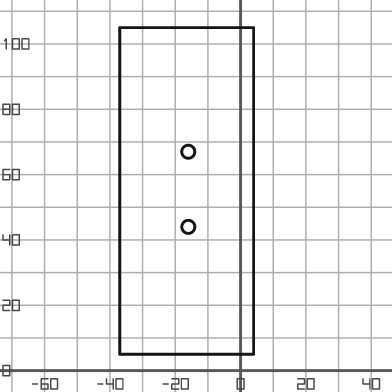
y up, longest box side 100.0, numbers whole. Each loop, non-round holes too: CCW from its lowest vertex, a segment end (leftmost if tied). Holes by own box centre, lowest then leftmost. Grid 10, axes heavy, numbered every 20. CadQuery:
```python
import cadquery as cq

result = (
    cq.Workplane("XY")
    .moveTo(-37.0, 5.0)
    .lineTo(4.0, 5.0)
    .lineTo(4.0, 105.0)
    .lineTo(-37.0, 105.0)
    .close()
    .moveTo(-16.0, 44.0)
    .circle(2.0)
    .moveTo(-16.0, 67.0)
    .circle(2.0)
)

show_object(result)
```